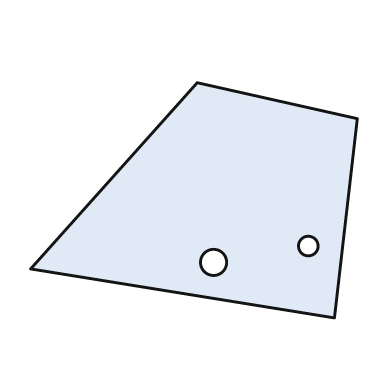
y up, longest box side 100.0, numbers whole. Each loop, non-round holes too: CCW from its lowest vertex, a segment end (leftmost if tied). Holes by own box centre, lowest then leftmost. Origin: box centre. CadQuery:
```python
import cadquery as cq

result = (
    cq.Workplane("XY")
    .moveTo(43.0, -36.0)
    .lineTo(50.0, 25.0)
    .lineTo(1.0, 36.0)
    .lineTo(-50.0, -21.0)
    .close()
    .moveTo(6.0, -19.0)
    .circle(4.0)
    .moveTo(35.0, -14.0)
    .circle(3.0)
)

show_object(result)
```